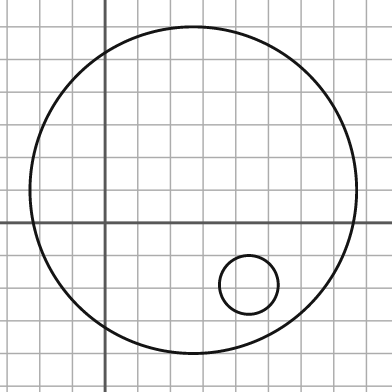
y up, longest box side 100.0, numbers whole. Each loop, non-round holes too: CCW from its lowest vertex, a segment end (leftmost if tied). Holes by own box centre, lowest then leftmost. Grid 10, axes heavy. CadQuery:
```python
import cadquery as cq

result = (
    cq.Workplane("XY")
    .moveTo(27.0, 10.0)
    .circle(50.0)
    .moveTo(44.0, -19.0)
    .circle(9.0)
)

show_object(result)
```